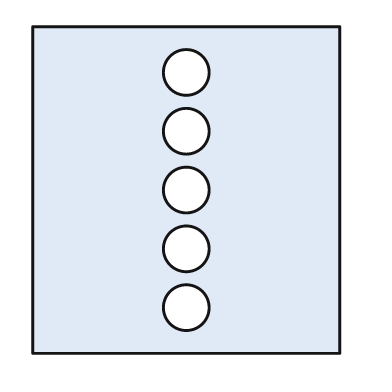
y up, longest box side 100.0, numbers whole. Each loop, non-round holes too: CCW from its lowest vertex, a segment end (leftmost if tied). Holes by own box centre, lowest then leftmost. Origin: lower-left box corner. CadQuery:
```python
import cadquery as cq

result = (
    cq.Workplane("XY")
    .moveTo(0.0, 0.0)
    .lineTo(94.0, 0.0)
    .lineTo(94.0, 100.0)
    .lineTo(0.0, 100.0)
    .close()
    .moveTo(47.0, 14.0)
    .circle(7.0)
    .moveTo(47.0, 32.0)
    .circle(7.0)
    .moveTo(47.0, 50.0)
    .circle(7.0)
    .moveTo(47.0, 68.0)
    .circle(7.0)
    .moveTo(47.0, 86.0)
    .circle(7.0)
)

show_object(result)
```